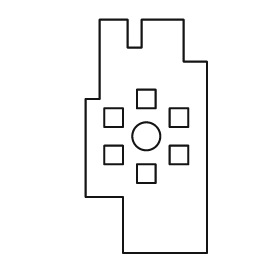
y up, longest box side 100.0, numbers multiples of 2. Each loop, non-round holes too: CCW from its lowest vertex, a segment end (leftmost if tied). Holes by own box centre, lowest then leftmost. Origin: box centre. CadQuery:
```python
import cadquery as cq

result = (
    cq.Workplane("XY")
    .moveTo(-10.0, -50.0)
    .lineTo(26.0, -50.0)
    .lineTo(26.0, 32.0)
    .lineTo(16.0, 32.0)
    .lineTo(16.0, 50.0)
    .lineTo(-2.0, 50.0)
    .lineTo(-2.0, 38.0)
    .lineTo(-8.0, 38.0)
    .lineTo(-8.0, 50.0)
    .lineTo(-20.0, 50.0)
    .lineTo(-20.0, 16.0)
    .lineTo(-26.0, 16.0)
    .lineTo(-26.0, -26.0)
    .lineTo(-10.0, -26.0)
    .close()
    .moveTo(-4.0, -20.0)
    .lineTo(4.0, -20.0)
    .lineTo(4.0, -12.0)
    .lineTo(-4.0, -12.0)
    .close()
    .moveTo(-18.0, -12.0)
    .lineTo(-10.0, -12.0)
    .lineTo(-10.0, -4.0)
    .lineTo(-18.0, -4.0)
    .close()
    .moveTo(10.0, -12.0)
    .lineTo(18.0, -12.0)
    .lineTo(18.0, -4.0)
    .lineTo(10.0, -4.0)
    .close()
    .moveTo(0.0, 0.0)
    .circle(6.0)
    .moveTo(-18.0, 4.0)
    .lineTo(-10.0, 4.0)
    .lineTo(-10.0, 12.0)
    .lineTo(-18.0, 12.0)
    .close()
    .moveTo(10.0, 4.0)
    .lineTo(18.0, 4.0)
    .lineTo(18.0, 12.0)
    .lineTo(10.0, 12.0)
    .close()
    .moveTo(-4.0, 12.0)
    .lineTo(4.0, 12.0)
    .lineTo(4.0, 20.0)
    .lineTo(-4.0, 20.0)
    .close()
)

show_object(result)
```